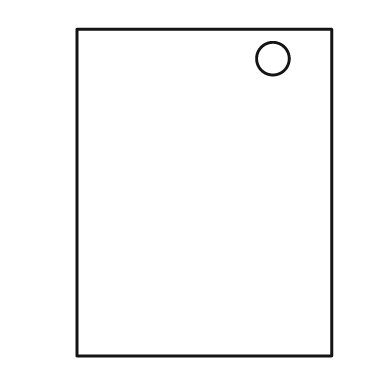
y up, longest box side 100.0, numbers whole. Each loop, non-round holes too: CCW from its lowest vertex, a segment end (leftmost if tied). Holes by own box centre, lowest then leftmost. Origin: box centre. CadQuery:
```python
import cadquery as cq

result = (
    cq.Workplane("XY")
    .moveTo(-39.0, -50.0)
    .lineTo(39.0, -50.0)
    .lineTo(39.0, 50.0)
    .lineTo(-39.0, 50.0)
    .close()
    .moveTo(21.0, 41.0)
    .circle(5.0)
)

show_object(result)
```